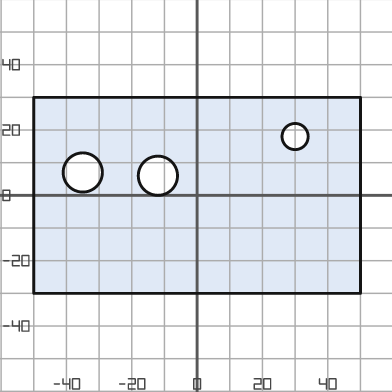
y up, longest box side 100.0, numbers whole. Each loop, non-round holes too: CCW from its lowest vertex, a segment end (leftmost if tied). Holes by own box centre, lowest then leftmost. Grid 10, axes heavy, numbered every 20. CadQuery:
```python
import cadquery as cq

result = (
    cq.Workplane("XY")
    .moveTo(-50.0, -30.0)
    .lineTo(50.0, -30.0)
    .lineTo(50.0, 30.0)
    .lineTo(-50.0, 30.0)
    .close()
    .moveTo(-12.0, 6.0)
    .circle(6.0)
    .moveTo(-35.0, 7.0)
    .circle(6.0)
    .moveTo(30.0, 18.0)
    .circle(4.0)
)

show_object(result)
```